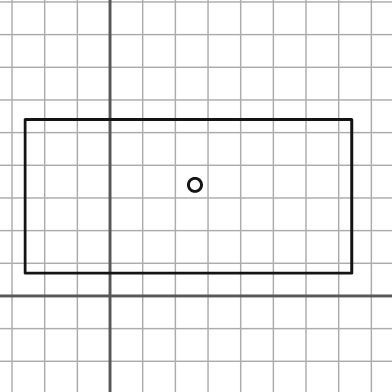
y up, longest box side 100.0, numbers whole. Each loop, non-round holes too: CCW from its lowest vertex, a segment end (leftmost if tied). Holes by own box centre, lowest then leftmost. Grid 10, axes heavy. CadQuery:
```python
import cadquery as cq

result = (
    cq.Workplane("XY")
    .moveTo(-26.0, 7.0)
    .lineTo(74.0, 7.0)
    .lineTo(74.0, 54.0)
    .lineTo(-26.0, 54.0)
    .close()
    .moveTo(26.0, 34.0)
    .circle(2.0)
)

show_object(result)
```